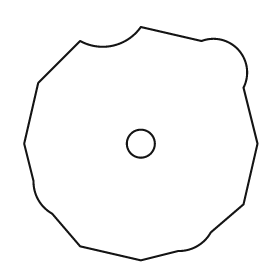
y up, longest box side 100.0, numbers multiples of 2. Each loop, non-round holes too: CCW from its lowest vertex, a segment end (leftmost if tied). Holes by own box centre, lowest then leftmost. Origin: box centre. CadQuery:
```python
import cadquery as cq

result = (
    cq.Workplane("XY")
    .moveTo(0.0, -50.0)
    .lineTo(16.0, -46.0)
    .threePointArc((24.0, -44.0), (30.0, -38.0))
    .lineTo(44.0, -26.0)
    .lineTo(50.0, 0.0)
    .lineTo(44.0, 24.0)
    .threePointArc((42.0, 40.0), (26.0, 44.0))
    .lineTo(0.0, 50.0)
    .threePointArc((-12.0, 42.0), (-26.0, 44.0))
    .lineTo(-44.0, 26.0)
    .lineTo(-50.0, 0.0)
    .lineTo(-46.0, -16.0)
    .threePointArc((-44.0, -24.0), (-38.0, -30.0))
    .lineTo(-26.0, -44.0)
    .close()
    .moveTo(0.0, 0.0)
    .circle(6.0)
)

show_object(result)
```